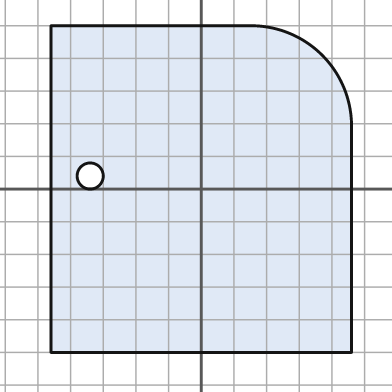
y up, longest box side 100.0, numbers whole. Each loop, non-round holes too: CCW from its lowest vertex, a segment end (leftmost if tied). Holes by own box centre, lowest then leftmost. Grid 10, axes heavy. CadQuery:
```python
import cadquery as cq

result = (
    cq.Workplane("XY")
    .moveTo(-46.0, -50.0)
    .lineTo(46.0, -50.0)
    .lineTo(46.0, 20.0)
    .threePointArc((37.0, 41.0), (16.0, 50.0))
    .lineTo(-46.0, 50.0)
    .close()
    .moveTo(-34.0, 4.0)
    .circle(4.0)
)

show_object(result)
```